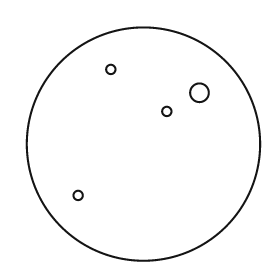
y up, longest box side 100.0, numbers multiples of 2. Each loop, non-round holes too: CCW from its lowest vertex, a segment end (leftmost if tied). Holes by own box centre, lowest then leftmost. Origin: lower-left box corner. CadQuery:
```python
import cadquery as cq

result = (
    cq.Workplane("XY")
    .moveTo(50.0, 50.0)
    .circle(50.0)
    .moveTo(22.0, 28.0)
    .circle(2.0)
    .moveTo(60.0, 64.0)
    .circle(2.0)
    .moveTo(74.0, 72.0)
    .circle(4.0)
    .moveTo(36.0, 82.0)
    .circle(2.0)
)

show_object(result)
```